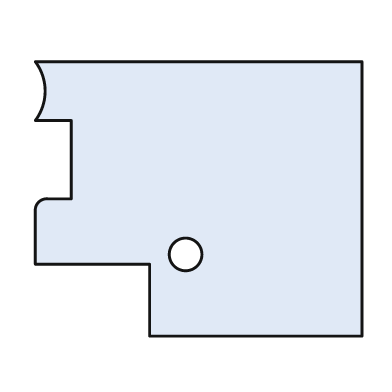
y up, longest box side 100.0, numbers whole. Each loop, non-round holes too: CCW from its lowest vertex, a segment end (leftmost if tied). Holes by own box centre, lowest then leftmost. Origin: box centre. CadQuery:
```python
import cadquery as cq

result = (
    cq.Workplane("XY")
    .moveTo(-15.0, -42.0)
    .lineTo(50.0, -42.0)
    .lineTo(50.0, 42.0)
    .lineTo(-50.0, 42.0)
    .threePointArc((-47.0, 33.0), (-50.0, 24.0))
    .lineTo(-39.0, 24.0)
    .lineTo(-39.0, 0.0)
    .lineTo(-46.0, 0.0)
    .threePointArc((-49.0, -1.0), (-50.0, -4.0))
    .lineTo(-50.0, -20.0)
    .lineTo(-15.0, -20.0)
    .close()
    .moveTo(-4.0, -17.0)
    .circle(5.0)
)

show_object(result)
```